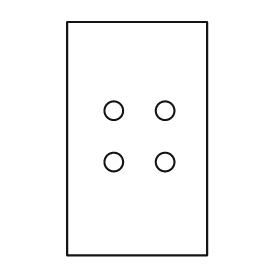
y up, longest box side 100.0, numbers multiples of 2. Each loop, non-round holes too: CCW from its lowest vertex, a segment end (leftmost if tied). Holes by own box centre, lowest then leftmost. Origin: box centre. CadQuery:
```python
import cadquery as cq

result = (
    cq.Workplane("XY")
    .moveTo(-30.0, -50.0)
    .lineTo(30.0, -50.0)
    .lineTo(30.0, 50.0)
    .lineTo(-30.0, 50.0)
    .close()
    .moveTo(-10.0, -10.0)
    .circle(4.0)
    .moveTo(12.0, -10.0)
    .circle(4.0)
    .moveTo(-10.0, 12.0)
    .circle(4.0)
    .moveTo(12.0, 12.0)
    .circle(4.0)
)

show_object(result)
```